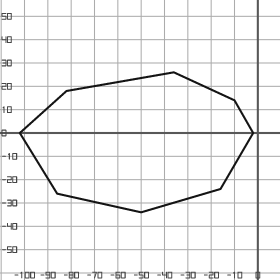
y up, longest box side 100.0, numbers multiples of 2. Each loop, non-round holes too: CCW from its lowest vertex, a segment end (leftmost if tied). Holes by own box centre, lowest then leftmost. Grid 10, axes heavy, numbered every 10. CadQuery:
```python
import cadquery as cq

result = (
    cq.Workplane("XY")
    .moveTo(-50.0, -34.0)
    .lineTo(-16.0, -24.0)
    .lineTo(-2.0, 0.0)
    .lineTo(-10.0, 14.0)
    .lineTo(-36.0, 26.0)
    .lineTo(-82.0, 18.0)
    .lineTo(-102.0, 0.0)
    .lineTo(-86.0, -26.0)
    .close()
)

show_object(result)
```